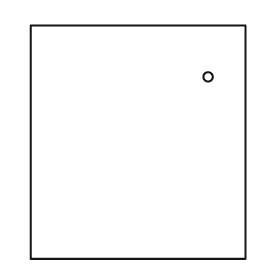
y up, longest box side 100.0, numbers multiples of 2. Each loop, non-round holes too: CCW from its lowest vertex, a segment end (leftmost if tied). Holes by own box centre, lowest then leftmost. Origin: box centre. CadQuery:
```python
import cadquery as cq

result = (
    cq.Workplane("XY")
    .moveTo(-46.0, -50.0)
    .lineTo(46.0, -50.0)
    .lineTo(46.0, 50.0)
    .lineTo(-46.0, 50.0)
    .close()
    .moveTo(30.0, 28.0)
    .circle(2.0)
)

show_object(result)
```